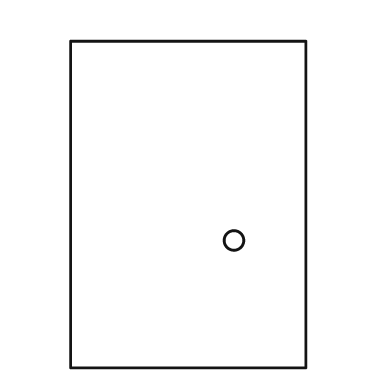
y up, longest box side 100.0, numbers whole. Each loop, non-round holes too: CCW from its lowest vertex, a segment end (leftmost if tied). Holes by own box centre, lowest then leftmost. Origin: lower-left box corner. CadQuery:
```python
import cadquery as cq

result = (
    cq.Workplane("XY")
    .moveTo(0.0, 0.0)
    .lineTo(72.0, 0.0)
    .lineTo(72.0, 100.0)
    .lineTo(0.0, 100.0)
    .close()
    .moveTo(50.0, 39.0)
    .circle(3.0)
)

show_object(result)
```